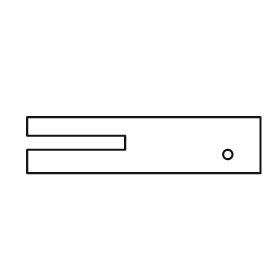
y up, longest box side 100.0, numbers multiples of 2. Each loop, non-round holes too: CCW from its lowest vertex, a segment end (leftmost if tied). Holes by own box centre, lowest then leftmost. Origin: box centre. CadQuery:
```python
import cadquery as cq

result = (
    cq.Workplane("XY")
    .moveTo(-50.0, -12.0)
    .lineTo(50.0, -12.0)
    .lineTo(50.0, 12.0)
    .lineTo(-50.0, 12.0)
    .lineTo(-50.0, 4.0)
    .lineTo(-8.0, 4.0)
    .lineTo(-8.0, -2.0)
    .lineTo(-50.0, -2.0)
    .close()
    .moveTo(36.0, -4.0)
    .circle(2.0)
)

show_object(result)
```